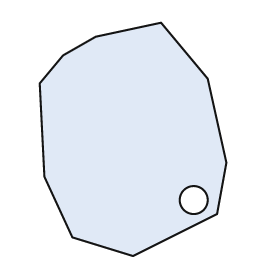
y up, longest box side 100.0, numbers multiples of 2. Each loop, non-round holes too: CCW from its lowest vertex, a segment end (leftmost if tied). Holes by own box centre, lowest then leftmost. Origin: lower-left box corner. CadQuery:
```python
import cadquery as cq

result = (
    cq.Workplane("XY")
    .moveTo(40.0, 0.0)
    .lineTo(76.0, 18.0)
    .lineTo(80.0, 40.0)
    .lineTo(72.0, 76.0)
    .lineTo(52.0, 100.0)
    .lineTo(24.0, 94.0)
    .lineTo(10.0, 86.0)
    .lineTo(0.0, 74.0)
    .lineTo(2.0, 34.0)
    .lineTo(14.0, 8.0)
    .close()
    .moveTo(66.0, 24.0)
    .circle(6.0)
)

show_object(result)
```